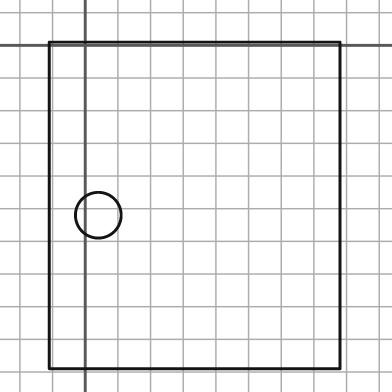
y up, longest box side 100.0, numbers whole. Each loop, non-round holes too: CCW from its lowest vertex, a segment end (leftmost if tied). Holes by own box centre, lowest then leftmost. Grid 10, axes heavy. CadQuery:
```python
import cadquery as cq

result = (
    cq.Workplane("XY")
    .moveTo(-11.0, -99.0)
    .lineTo(78.0, -99.0)
    .lineTo(78.0, 1.0)
    .lineTo(-11.0, 1.0)
    .close()
    .moveTo(4.0, -52.0)
    .circle(7.0)
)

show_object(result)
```